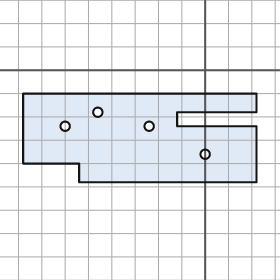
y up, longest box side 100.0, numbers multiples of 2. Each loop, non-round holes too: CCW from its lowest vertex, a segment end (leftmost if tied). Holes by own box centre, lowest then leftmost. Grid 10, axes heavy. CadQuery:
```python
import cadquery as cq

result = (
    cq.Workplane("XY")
    .moveTo(-54.0, -48.0)
    .lineTo(22.0, -48.0)
    .lineTo(22.0, -24.0)
    .lineTo(-12.0, -24.0)
    .lineTo(-12.0, -18.0)
    .lineTo(22.0, -18.0)
    .lineTo(22.0, -10.0)
    .lineTo(-78.0, -10.0)
    .lineTo(-78.0, -40.0)
    .lineTo(-54.0, -40.0)
    .close()
    .moveTo(0.0, -36.0)
    .circle(2.0)
    .moveTo(-60.0, -24.0)
    .circle(2.0)
    .moveTo(-24.0, -24.0)
    .circle(2.0)
    .moveTo(-46.0, -18.0)
    .circle(2.0)
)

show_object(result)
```